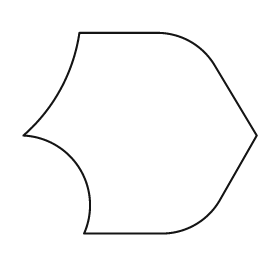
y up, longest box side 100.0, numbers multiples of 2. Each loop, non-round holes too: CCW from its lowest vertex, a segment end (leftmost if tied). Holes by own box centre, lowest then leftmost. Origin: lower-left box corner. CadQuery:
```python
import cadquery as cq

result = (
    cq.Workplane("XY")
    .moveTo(26.0, 0.0)
    .lineTo(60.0, 0.0)
    .threePointArc((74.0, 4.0), (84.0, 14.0))
    .lineTo(100.0, 42.0)
    .lineTo(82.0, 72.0)
    .threePointArc((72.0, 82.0), (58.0, 86.0))
    .lineTo(24.0, 86.0)
    .threePointArc((16.0, 62.0), (0.0, 42.0))
    .threePointArc((24.0, 28.0), (26.0, 0.0))
    .close()
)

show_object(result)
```